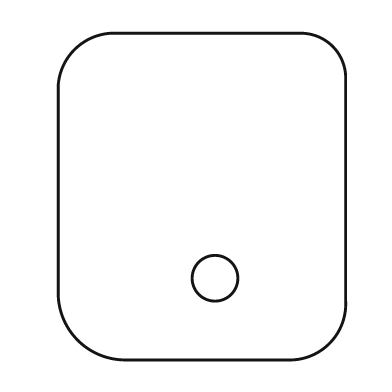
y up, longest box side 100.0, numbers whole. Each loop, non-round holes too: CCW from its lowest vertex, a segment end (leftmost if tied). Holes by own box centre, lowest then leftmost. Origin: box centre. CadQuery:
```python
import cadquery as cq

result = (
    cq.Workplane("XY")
    .moveTo(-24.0, -50.0)
    .lineTo(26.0, -50.0)
    .threePointArc((39.0, -45.0), (44.0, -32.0))
    .lineTo(44.0, 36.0)
    .threePointArc((40.0, 46.0), (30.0, 50.0))
    .lineTo(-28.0, 50.0)
    .threePointArc((-39.0, 45.0), (-44.0, 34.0))
    .lineTo(-44.0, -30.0)
    .threePointArc((-38.0, -44.0), (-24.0, -50.0))
    .close()
    .moveTo(4.0, -25.0)
    .circle(7.0)
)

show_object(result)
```